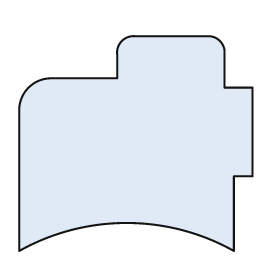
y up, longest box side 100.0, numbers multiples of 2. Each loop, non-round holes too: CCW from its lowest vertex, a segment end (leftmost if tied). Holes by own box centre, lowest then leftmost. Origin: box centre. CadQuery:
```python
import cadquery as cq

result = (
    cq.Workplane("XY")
    .moveTo(-50.0, -46.0)
    .threePointArc((-4.0, -34.0), (42.0, -46.0))
    .lineTo(42.0, -14.0)
    .lineTo(50.0, -14.0)
    .lineTo(50.0, 24.0)
    .lineTo(38.0, 24.0)
    .lineTo(38.0, 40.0)
    .threePointArc((36.0, 44.0), (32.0, 46.0))
    .lineTo(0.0, 46.0)
    .threePointArc((-6.0, 44.0), (-8.0, 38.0))
    .lineTo(-8.0, 28.0)
    .lineTo(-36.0, 28.0)
    .threePointArc((-46.0, 24.0), (-50.0, 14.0))
    .close()
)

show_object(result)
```